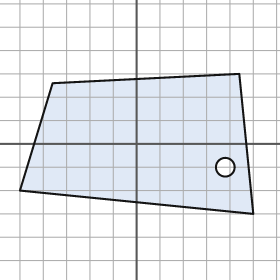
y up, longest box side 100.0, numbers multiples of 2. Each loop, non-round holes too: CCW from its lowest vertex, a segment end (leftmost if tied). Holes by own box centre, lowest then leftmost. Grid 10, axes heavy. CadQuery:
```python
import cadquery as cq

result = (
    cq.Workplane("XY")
    .moveTo(50.0, -30.0)
    .lineTo(44.0, 30.0)
    .lineTo(-36.0, 26.0)
    .lineTo(-50.0, -20.0)
    .close()
    .moveTo(38.0, -10.0)
    .circle(4.0)
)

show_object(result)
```